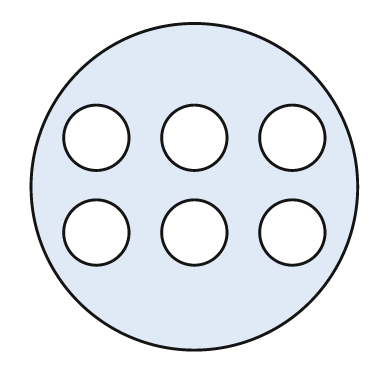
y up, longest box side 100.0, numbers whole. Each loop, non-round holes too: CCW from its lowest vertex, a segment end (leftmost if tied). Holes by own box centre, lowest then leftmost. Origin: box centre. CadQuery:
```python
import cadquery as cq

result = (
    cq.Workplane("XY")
    .moveTo(0.0, 0.0)
    .circle(50.0)
    .moveTo(-30.0, -14.0)
    .circle(10.0)
    .moveTo(0.0, -14.0)
    .circle(10.0)
    .moveTo(30.0, -14.0)
    .circle(10.0)
    .moveTo(-30.0, 15.0)
    .circle(10.0)
    .moveTo(0.0, 15.0)
    .circle(10.0)
    .moveTo(30.0, 15.0)
    .circle(10.0)
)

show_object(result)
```